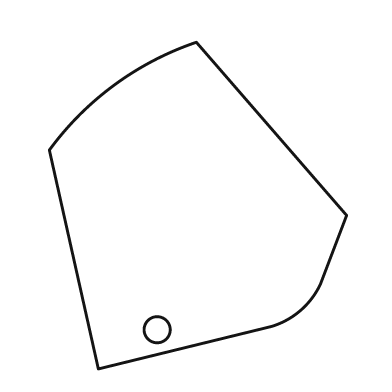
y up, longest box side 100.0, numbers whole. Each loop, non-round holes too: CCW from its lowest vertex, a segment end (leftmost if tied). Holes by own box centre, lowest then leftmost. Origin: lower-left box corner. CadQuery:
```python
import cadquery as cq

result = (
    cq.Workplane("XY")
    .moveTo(15.0, 0.0)
    .lineTo(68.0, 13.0)
    .threePointArc((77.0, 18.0), (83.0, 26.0))
    .lineTo(91.0, 47.0)
    .lineTo(45.0, 100.0)
    .threePointArc((20.0, 87.0), (0.0, 67.0))
    .close()
    .moveTo(33.0, 12.0)
    .circle(4.0)
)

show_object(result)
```